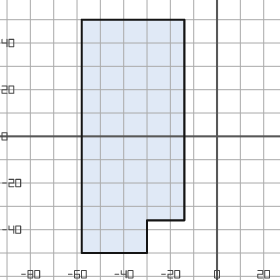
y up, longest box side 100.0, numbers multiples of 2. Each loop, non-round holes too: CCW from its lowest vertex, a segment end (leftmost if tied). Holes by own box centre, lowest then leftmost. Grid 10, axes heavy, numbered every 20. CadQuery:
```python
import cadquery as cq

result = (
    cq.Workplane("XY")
    .moveTo(-58.0, -50.0)
    .lineTo(-30.0, -50.0)
    .lineTo(-30.0, -36.0)
    .lineTo(-14.0, -36.0)
    .lineTo(-14.0, 50.0)
    .lineTo(-58.0, 50.0)
    .close()
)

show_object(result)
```